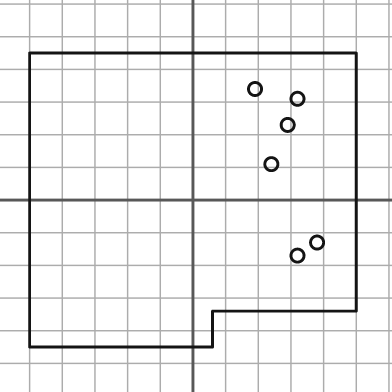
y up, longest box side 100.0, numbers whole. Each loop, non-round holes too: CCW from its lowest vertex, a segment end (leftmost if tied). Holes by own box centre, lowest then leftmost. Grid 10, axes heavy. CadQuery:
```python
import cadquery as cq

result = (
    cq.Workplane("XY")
    .moveTo(-50.0, -45.0)
    .lineTo(6.0, -45.0)
    .lineTo(6.0, -34.0)
    .lineTo(50.0, -34.0)
    .lineTo(50.0, 45.0)
    .lineTo(-50.0, 45.0)
    .close()
    .moveTo(32.0, -17.0)
    .circle(2.0)
    .moveTo(38.0, -13.0)
    .circle(2.0)
    .moveTo(24.0, 11.0)
    .circle(2.0)
    .moveTo(29.0, 23.0)
    .circle(2.0)
    .moveTo(32.0, 31.0)
    .circle(2.0)
    .moveTo(19.0, 34.0)
    .circle(2.0)
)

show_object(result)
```